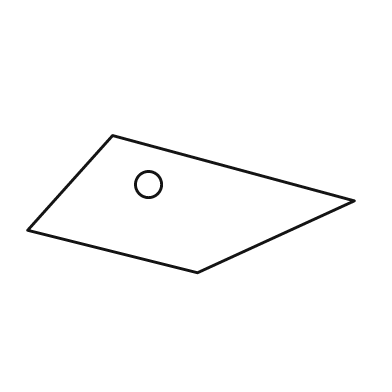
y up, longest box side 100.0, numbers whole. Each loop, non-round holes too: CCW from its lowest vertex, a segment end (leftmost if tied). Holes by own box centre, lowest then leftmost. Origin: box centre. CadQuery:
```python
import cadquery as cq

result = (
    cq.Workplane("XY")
    .moveTo(2.0, -21.0)
    .lineTo(50.0, 1.0)
    .lineTo(-24.0, 21.0)
    .lineTo(-50.0, -8.0)
    .close()
    .moveTo(-13.0, 6.0)
    .circle(4.0)
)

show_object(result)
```